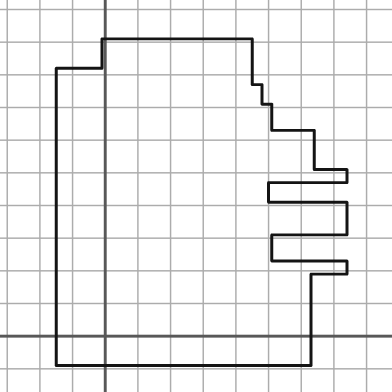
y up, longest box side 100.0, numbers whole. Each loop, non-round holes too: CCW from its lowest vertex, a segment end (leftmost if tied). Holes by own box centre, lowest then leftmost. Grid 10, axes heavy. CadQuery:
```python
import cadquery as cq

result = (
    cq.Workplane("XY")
    .moveTo(-15.0, -9.0)
    .lineTo(63.0, -9.0)
    .lineTo(63.0, 19.0)
    .lineTo(74.0, 19.0)
    .lineTo(74.0, 23.0)
    .lineTo(51.0, 23.0)
    .lineTo(51.0, 31.0)
    .lineTo(74.0, 31.0)
    .lineTo(74.0, 41.0)
    .lineTo(50.0, 41.0)
    .lineTo(50.0, 47.0)
    .lineTo(74.0, 47.0)
    .lineTo(74.0, 51.0)
    .lineTo(64.0, 51.0)
    .lineTo(64.0, 63.0)
    .lineTo(51.0, 63.0)
    .lineTo(51.0, 71.0)
    .lineTo(48.0, 71.0)
    .lineTo(48.0, 77.0)
    .lineTo(45.0, 77.0)
    .lineTo(45.0, 91.0)
    .lineTo(-1.0, 91.0)
    .lineTo(-1.0, 82.0)
    .lineTo(-15.0, 82.0)
    .close()
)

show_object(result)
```